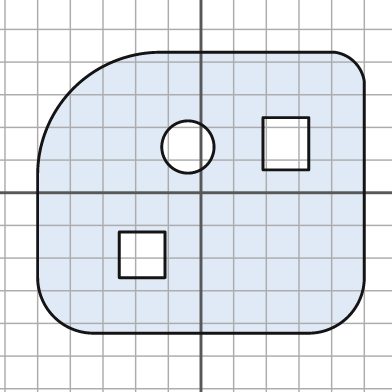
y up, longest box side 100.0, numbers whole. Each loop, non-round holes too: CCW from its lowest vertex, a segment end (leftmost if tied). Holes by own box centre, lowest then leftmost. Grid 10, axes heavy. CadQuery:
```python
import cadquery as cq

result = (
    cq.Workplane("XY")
    .moveTo(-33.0, -43.0)
    .lineTo(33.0, -43.0)
    .threePointArc((45.0, -38.0), (50.0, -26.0))
    .lineTo(50.0, 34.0)
    .threePointArc((47.0, 40.0), (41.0, 43.0))
    .lineTo(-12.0, 43.0)
    .threePointArc((-39.0, 32.0), (-50.0, 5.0))
    .lineTo(-50.0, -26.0)
    .threePointArc((-45.0, -38.0), (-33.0, -43.0))
    .close()
    .moveTo(-25.0, -26.0)
    .lineTo(-11.0, -26.0)
    .lineTo(-11.0, -12.0)
    .lineTo(-25.0, -12.0)
    .close()
    .moveTo(-4.0, 14.0)
    .circle(8.0)
    .moveTo(19.0, 7.0)
    .lineTo(33.0, 7.0)
    .lineTo(33.0, 23.0)
    .lineTo(19.0, 23.0)
    .close()
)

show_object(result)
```